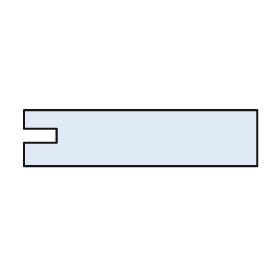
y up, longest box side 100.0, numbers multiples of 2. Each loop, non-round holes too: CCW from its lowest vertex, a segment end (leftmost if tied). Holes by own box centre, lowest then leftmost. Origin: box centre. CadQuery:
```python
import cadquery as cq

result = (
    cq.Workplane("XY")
    .moveTo(-50.0, -12.0)
    .lineTo(50.0, -12.0)
    .lineTo(50.0, 12.0)
    .lineTo(-50.0, 12.0)
    .lineTo(-50.0, 4.0)
    .lineTo(-36.0, 4.0)
    .lineTo(-36.0, -2.0)
    .lineTo(-50.0, -2.0)
    .close()
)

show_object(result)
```